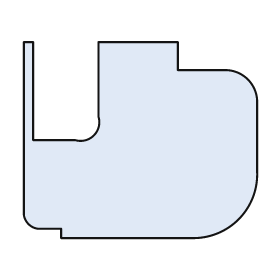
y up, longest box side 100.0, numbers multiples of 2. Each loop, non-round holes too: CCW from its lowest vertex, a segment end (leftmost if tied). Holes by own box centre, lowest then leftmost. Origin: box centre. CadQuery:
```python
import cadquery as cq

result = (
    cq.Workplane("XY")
    .moveTo(-34.0, -42.0)
    .lineTo(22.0, -42.0)
    .threePointArc((42.0, -34.0), (50.0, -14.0))
    .lineTo(50.0, 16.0)
    .threePointArc((46.0, 26.0), (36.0, 30.0))
    .lineTo(16.0, 30.0)
    .lineTo(16.0, 42.0)
    .lineTo(-18.0, 42.0)
    .lineTo(-18.0, 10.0)
    .threePointArc((-20.0, 2.0), (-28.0, 0.0))
    .lineTo(-46.0, 0.0)
    .lineTo(-46.0, 42.0)
    .lineTo(-50.0, 42.0)
    .lineTo(-50.0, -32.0)
    .threePointArc((-48.0, -36.0), (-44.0, -38.0))
    .lineTo(-34.0, -38.0)
    .close()
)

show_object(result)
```